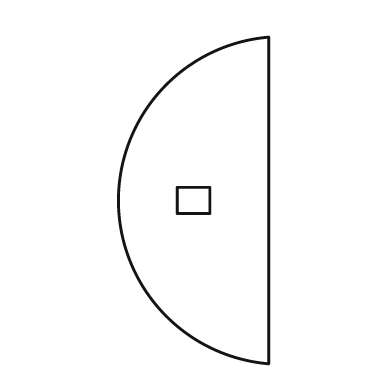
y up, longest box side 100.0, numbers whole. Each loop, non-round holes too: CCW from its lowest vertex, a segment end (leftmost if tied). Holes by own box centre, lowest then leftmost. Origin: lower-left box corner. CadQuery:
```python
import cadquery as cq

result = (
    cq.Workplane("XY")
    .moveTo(46.0, 0.0)
    .lineTo(46.0, 100.0)
    .threePointArc((0.0, 50.0), (46.0, 0.0))
    .close()
    .moveTo(18.0, 46.0)
    .lineTo(28.0, 46.0)
    .lineTo(28.0, 54.0)
    .lineTo(18.0, 54.0)
    .close()
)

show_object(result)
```